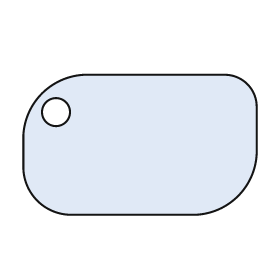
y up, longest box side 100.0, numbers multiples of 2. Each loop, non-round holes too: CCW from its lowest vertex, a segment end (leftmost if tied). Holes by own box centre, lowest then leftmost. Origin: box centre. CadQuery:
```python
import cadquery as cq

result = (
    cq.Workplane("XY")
    .moveTo(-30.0, -30.0)
    .lineTo(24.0, -30.0)
    .threePointArc((42.0, -22.0), (50.0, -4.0))
    .lineTo(50.0, 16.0)
    .threePointArc((46.0, 26.0), (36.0, 30.0))
    .lineTo(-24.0, 30.0)
    .threePointArc((-42.0, 22.0), (-50.0, 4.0))
    .lineTo(-50.0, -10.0)
    .threePointArc((-44.0, -24.0), (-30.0, -30.0))
    .close()
    .moveTo(-36.0, 14.0)
    .circle(6.0)
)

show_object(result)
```